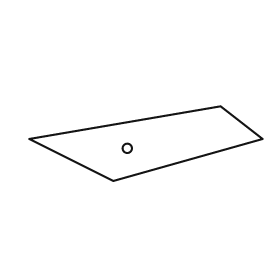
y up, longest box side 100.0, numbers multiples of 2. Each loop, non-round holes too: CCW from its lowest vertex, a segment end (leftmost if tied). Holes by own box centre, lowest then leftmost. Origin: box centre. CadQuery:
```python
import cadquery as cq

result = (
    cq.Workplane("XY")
    .moveTo(-14.0, -16.0)
    .lineTo(50.0, 2.0)
    .lineTo(32.0, 16.0)
    .lineTo(-50.0, 2.0)
    .close()
    .moveTo(-8.0, -2.0)
    .circle(2.0)
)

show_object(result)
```